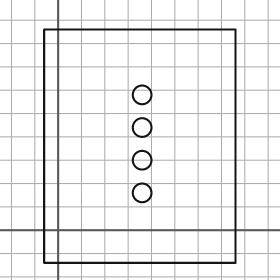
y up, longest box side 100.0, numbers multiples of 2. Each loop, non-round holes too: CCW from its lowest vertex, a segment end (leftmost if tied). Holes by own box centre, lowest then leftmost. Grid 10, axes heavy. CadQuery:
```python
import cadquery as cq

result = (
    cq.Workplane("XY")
    .moveTo(-6.0, -14.0)
    .lineTo(76.0, -14.0)
    .lineTo(76.0, 86.0)
    .lineTo(-6.0, 86.0)
    .close()
    .moveTo(36.0, 16.0)
    .circle(4.0)
    .moveTo(36.0, 30.0)
    .circle(4.0)
    .moveTo(36.0, 44.0)
    .circle(4.0)
    .moveTo(36.0, 58.0)
    .circle(4.0)
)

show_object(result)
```